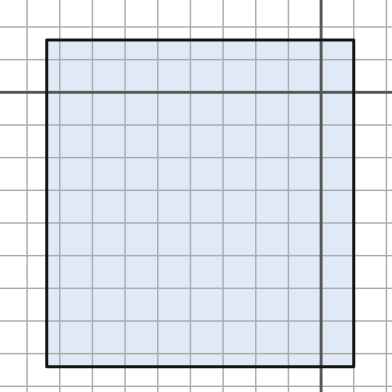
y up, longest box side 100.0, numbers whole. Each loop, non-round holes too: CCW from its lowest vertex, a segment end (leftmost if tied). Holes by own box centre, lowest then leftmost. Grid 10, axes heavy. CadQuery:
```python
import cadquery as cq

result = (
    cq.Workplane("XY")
    .moveTo(-84.0, -84.0)
    .lineTo(10.0, -84.0)
    .lineTo(10.0, 16.0)
    .lineTo(-84.0, 16.0)
    .close()
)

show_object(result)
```